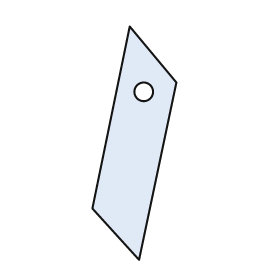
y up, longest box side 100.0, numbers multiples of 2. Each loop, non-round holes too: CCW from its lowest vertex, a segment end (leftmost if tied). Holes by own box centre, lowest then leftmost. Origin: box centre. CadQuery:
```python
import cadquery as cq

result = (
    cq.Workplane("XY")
    .moveTo(2.0, -50.0)
    .lineTo(18.0, 26.0)
    .lineTo(-2.0, 50.0)
    .lineTo(-18.0, -28.0)
    .close()
    .moveTo(4.0, 22.0)
    .circle(4.0)
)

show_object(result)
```